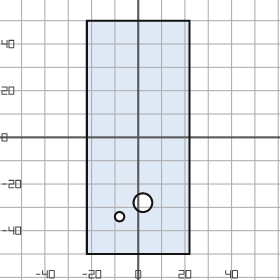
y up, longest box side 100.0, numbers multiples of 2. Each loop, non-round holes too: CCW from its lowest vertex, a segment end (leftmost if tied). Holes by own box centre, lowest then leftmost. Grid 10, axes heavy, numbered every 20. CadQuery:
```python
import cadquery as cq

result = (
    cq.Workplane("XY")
    .moveTo(-22.0, -50.0)
    .lineTo(22.0, -50.0)
    .lineTo(22.0, 50.0)
    .lineTo(-22.0, 50.0)
    .close()
    .moveTo(-8.0, -34.0)
    .circle(2.0)
    .moveTo(2.0, -28.0)
    .circle(4.0)
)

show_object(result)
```